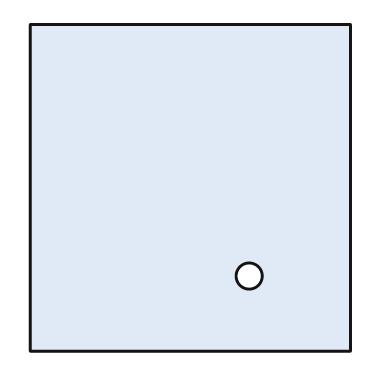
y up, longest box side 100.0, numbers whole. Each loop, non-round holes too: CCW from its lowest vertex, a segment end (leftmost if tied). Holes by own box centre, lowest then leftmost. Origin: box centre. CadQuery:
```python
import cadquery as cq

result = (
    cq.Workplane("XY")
    .moveTo(-49.0, -50.0)
    .lineTo(49.0, -50.0)
    .lineTo(49.0, 50.0)
    .lineTo(-49.0, 50.0)
    .close()
    .moveTo(18.0, -27.0)
    .circle(4.0)
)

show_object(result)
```